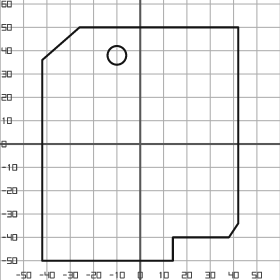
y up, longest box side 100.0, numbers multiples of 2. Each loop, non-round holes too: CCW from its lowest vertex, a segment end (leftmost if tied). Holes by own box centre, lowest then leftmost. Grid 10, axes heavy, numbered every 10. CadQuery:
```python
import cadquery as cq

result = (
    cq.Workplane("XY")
    .moveTo(-42.0, -50.0)
    .lineTo(14.0, -50.0)
    .lineTo(14.0, -40.0)
    .lineTo(38.0, -40.0)
    .lineTo(42.0, -34.0)
    .lineTo(42.0, 50.0)
    .lineTo(-26.0, 50.0)
    .lineTo(-42.0, 36.0)
    .close()
    .moveTo(-10.0, 38.0)
    .circle(4.0)
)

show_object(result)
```